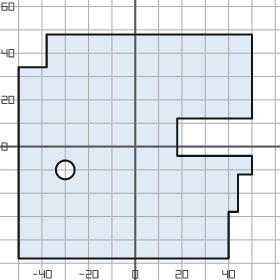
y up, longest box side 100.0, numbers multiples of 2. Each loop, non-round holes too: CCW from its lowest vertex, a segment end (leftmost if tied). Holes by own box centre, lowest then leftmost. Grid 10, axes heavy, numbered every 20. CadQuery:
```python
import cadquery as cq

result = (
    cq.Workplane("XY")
    .moveTo(-50.0, -48.0)
    .lineTo(40.0, -48.0)
    .lineTo(40.0, -28.0)
    .lineTo(44.0, -28.0)
    .lineTo(44.0, -12.0)
    .lineTo(50.0, -12.0)
    .lineTo(50.0, -4.0)
    .lineTo(18.0, -4.0)
    .lineTo(18.0, 12.0)
    .lineTo(50.0, 12.0)
    .lineTo(50.0, 48.0)
    .lineTo(-38.0, 48.0)
    .lineTo(-38.0, 34.0)
    .lineTo(-50.0, 34.0)
    .close()
    .moveTo(-30.0, -10.0)
    .circle(4.0)
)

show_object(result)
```